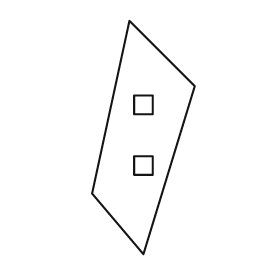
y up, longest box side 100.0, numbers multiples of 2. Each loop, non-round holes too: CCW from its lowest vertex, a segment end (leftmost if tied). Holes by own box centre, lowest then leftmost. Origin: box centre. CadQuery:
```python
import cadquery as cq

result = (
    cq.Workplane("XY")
    .moveTo(0.0, -50.0)
    .lineTo(22.0, 22.0)
    .lineTo(-6.0, 50.0)
    .lineTo(-22.0, -24.0)
    .close()
    .moveTo(-4.0, -16.0)
    .lineTo(4.0, -16.0)
    .lineTo(4.0, -8.0)
    .lineTo(-4.0, -8.0)
    .close()
    .moveTo(-4.0, 10.0)
    .lineTo(4.0, 10.0)
    .lineTo(4.0, 18.0)
    .lineTo(-4.0, 18.0)
    .close()
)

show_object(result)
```